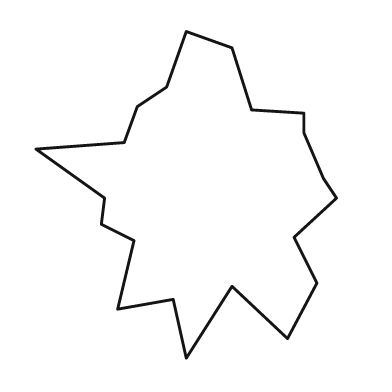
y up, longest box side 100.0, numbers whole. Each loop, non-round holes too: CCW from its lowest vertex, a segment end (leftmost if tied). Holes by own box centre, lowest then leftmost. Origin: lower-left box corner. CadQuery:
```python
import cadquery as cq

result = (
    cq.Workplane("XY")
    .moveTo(46.0, 0.0)
    .lineTo(60.0, 22.0)
    .lineTo(77.0, 6.0)
    .lineTo(86.0, 23.0)
    .lineTo(79.0, 37.0)
    .lineTo(92.0, 49.0)
    .lineTo(88.0, 55.0)
    .lineTo(82.0, 69.0)
    .lineTo(82.0, 75.0)
    .lineTo(66.0, 76.0)
    .lineTo(60.0, 95.0)
    .lineTo(46.0, 100.0)
    .lineTo(40.0, 83.0)
    .lineTo(31.0, 77.0)
    .lineTo(27.0, 66.0)
    .lineTo(0.0, 64.0)
    .lineTo(21.0, 49.0)
    .lineTo(20.0, 41.0)
    .lineTo(30.0, 36.0)
    .lineTo(25.0, 15.0)
    .lineTo(42.0, 18.0)
    .close()
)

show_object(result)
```